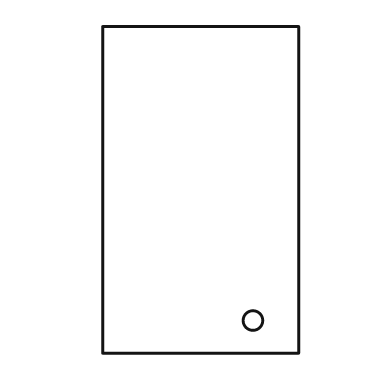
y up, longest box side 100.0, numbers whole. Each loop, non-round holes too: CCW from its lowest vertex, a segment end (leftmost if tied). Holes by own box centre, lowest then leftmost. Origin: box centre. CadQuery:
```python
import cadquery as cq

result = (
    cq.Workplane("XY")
    .moveTo(-30.0, -50.0)
    .lineTo(30.0, -50.0)
    .lineTo(30.0, 50.0)
    .lineTo(-30.0, 50.0)
    .close()
    .moveTo(16.0, -40.0)
    .circle(3.0)
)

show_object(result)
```